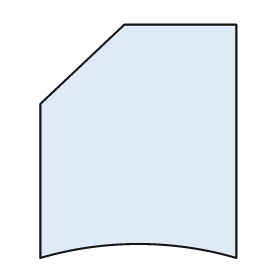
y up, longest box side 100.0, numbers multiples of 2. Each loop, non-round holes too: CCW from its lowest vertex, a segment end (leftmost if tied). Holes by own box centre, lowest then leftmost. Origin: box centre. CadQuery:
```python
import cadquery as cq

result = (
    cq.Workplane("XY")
    .moveTo(-42.0, -50.0)
    .threePointArc((0.0, -44.0), (42.0, -50.0))
    .lineTo(42.0, 50.0)
    .lineTo(-6.0, 50.0)
    .lineTo(-42.0, 16.0)
    .close()
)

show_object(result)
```